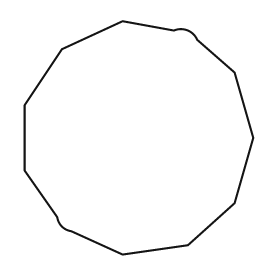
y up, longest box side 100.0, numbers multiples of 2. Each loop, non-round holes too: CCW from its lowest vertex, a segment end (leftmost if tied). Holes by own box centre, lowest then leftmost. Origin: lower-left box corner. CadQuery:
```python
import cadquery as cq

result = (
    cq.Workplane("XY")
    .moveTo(42.0, 0.0)
    .lineTo(70.0, 4.0)
    .lineTo(90.0, 22.0)
    .lineTo(98.0, 50.0)
    .lineTo(90.0, 78.0)
    .lineTo(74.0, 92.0)
    .threePointArc((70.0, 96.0), (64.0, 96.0))
    .lineTo(42.0, 100.0)
    .lineTo(16.0, 88.0)
    .lineTo(0.0, 64.0)
    .lineTo(0.0, 36.0)
    .lineTo(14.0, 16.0)
    .threePointArc((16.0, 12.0), (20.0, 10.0))
    .close()
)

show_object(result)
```